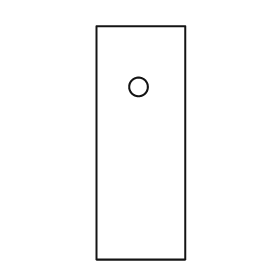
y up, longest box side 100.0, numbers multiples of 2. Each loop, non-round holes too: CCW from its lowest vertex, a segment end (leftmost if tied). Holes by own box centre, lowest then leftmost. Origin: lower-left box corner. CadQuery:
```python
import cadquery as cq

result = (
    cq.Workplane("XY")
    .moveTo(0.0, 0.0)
    .lineTo(38.0, 0.0)
    .lineTo(38.0, 100.0)
    .lineTo(0.0, 100.0)
    .close()
    .moveTo(18.0, 74.0)
    .circle(4.0)
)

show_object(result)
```